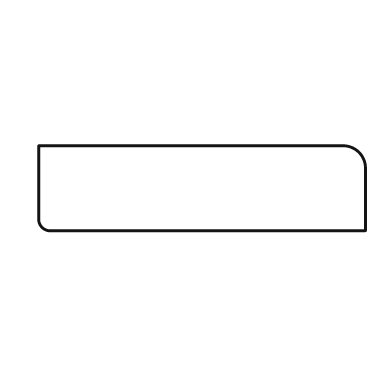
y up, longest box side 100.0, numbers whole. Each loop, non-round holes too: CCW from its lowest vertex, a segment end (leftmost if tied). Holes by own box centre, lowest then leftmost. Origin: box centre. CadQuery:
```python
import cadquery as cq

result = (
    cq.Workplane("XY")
    .moveTo(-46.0, -13.0)
    .lineTo(50.0, -13.0)
    .lineTo(50.0, 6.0)
    .threePointArc((48.0, 11.0), (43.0, 13.0))
    .lineTo(-50.0, 13.0)
    .lineTo(-50.0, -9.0)
    .threePointArc((-49.0, -12.0), (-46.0, -13.0))
    .close()
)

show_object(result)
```